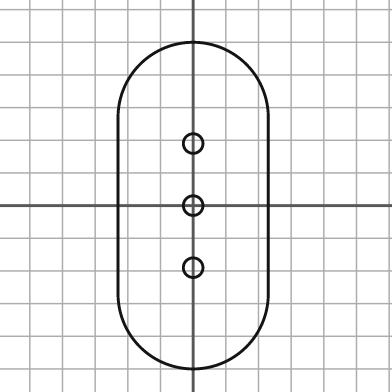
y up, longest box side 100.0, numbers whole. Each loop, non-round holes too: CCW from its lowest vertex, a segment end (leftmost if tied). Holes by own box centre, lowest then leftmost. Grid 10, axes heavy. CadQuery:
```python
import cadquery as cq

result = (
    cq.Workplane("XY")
    .moveTo(-23.0, -27.0)
    .threePointArc((0.0, -50.0), (23.0, -27.0))
    .lineTo(23.0, 27.0)
    .threePointArc((0.0, 50.0), (-23.0, 27.0))
    .close()
    .moveTo(0.0, -19.0)
    .circle(3.0)
    .moveTo(0.0, 0.0)
    .circle(3.0)
    .moveTo(0.0, 19.0)
    .circle(3.0)
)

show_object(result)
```